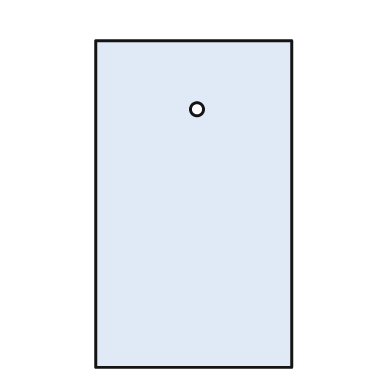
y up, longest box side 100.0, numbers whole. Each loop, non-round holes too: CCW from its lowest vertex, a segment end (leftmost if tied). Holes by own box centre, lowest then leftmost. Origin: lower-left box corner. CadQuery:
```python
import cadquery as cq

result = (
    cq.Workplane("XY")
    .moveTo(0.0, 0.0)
    .lineTo(60.0, 0.0)
    .lineTo(60.0, 100.0)
    .lineTo(0.0, 100.0)
    .close()
    .moveTo(31.0, 79.0)
    .circle(2.0)
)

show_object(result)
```